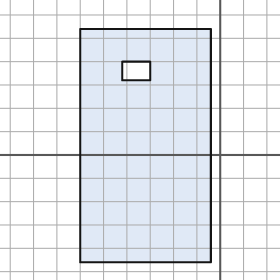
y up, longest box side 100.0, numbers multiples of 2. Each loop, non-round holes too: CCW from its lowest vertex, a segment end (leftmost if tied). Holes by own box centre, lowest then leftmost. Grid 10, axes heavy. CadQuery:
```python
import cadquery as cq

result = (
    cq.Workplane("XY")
    .moveTo(-60.0, -46.0)
    .lineTo(-4.0, -46.0)
    .lineTo(-4.0, 54.0)
    .lineTo(-60.0, 54.0)
    .close()
    .moveTo(-42.0, 32.0)
    .lineTo(-30.0, 32.0)
    .lineTo(-30.0, 40.0)
    .lineTo(-42.0, 40.0)
    .close()
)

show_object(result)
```